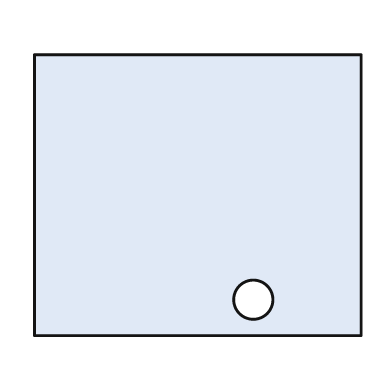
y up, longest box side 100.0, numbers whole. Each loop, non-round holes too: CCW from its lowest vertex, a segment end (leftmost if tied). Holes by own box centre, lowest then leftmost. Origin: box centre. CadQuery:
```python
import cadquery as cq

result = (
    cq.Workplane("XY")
    .moveTo(-50.0, -43.0)
    .lineTo(50.0, -43.0)
    .lineTo(50.0, 43.0)
    .lineTo(-50.0, 43.0)
    .close()
    .moveTo(17.0, -32.0)
    .circle(6.0)
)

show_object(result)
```